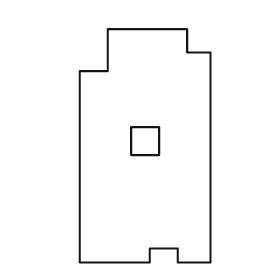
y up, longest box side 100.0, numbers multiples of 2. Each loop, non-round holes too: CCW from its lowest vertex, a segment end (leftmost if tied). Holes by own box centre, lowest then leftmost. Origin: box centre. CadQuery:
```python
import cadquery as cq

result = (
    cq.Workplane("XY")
    .moveTo(-28.0, -50.0)
    .lineTo(2.0, -50.0)
    .lineTo(2.0, -44.0)
    .lineTo(14.0, -44.0)
    .lineTo(14.0, -50.0)
    .lineTo(28.0, -50.0)
    .lineTo(28.0, 40.0)
    .lineTo(18.0, 40.0)
    .lineTo(18.0, 50.0)
    .lineTo(-16.0, 50.0)
    .lineTo(-16.0, 32.0)
    .lineTo(-28.0, 32.0)
    .close()
    .moveTo(-6.0, -4.0)
    .lineTo(6.0, -4.0)
    .lineTo(6.0, 8.0)
    .lineTo(-6.0, 8.0)
    .close()
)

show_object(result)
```